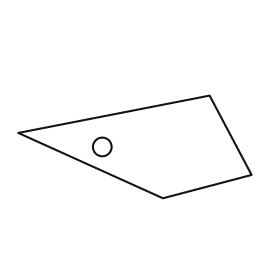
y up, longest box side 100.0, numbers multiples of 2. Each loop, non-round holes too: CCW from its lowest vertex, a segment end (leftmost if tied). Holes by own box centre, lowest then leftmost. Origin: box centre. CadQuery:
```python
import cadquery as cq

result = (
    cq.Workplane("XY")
    .moveTo(12.0, -22.0)
    .lineTo(50.0, -12.0)
    .lineTo(32.0, 22.0)
    .lineTo(-50.0, 6.0)
    .close()
    .moveTo(-14.0, 0.0)
    .circle(4.0)
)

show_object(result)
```